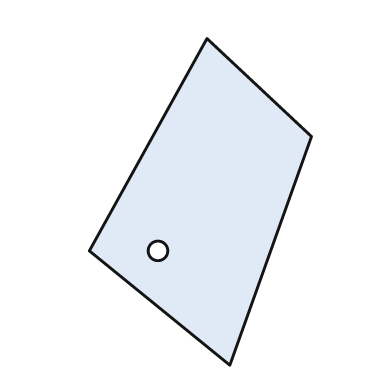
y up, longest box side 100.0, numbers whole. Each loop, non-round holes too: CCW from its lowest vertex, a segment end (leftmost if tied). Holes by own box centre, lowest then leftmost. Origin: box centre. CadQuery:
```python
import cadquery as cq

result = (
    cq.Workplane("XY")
    .moveTo(9.0, -50.0)
    .lineTo(34.0, 20.0)
    .lineTo(2.0, 50.0)
    .lineTo(-34.0, -15.0)
    .close()
    .moveTo(-13.0, -15.0)
    .circle(3.0)
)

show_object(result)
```